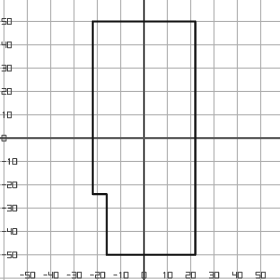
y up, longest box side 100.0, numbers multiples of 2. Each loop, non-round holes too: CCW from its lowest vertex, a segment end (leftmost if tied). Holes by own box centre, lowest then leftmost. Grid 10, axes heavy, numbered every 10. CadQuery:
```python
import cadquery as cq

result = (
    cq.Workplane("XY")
    .moveTo(-16.0, -50.0)
    .lineTo(22.0, -50.0)
    .lineTo(22.0, 50.0)
    .lineTo(-22.0, 50.0)
    .lineTo(-22.0, -24.0)
    .lineTo(-16.0, -24.0)
    .close()
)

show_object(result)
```